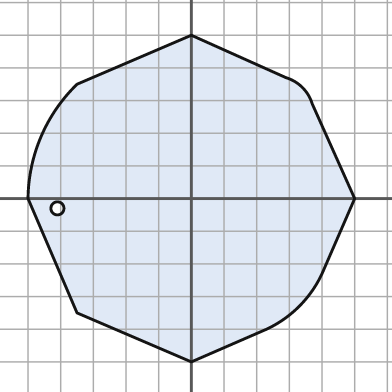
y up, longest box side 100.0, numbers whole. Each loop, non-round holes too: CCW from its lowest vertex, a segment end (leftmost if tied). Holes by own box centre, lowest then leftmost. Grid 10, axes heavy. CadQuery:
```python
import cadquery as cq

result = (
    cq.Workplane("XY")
    .moveTo(0.0, -50.0)
    .lineTo(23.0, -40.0)
    .threePointArc((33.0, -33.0), (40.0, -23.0))
    .lineTo(50.0, 0.0)
    .lineTo(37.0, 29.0)
    .threePointArc((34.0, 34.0), (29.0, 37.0))
    .lineTo(0.0, 50.0)
    .lineTo(-35.0, 35.0)
    .threePointArc((-46.0, 19.0), (-50.0, 0.0))
    .lineTo(-35.0, -35.0)
    .close()
    .moveTo(-41.0, -3.0)
    .circle(2.0)
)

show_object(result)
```